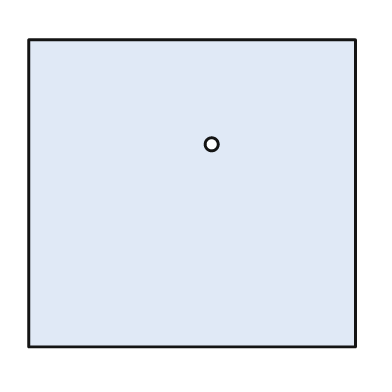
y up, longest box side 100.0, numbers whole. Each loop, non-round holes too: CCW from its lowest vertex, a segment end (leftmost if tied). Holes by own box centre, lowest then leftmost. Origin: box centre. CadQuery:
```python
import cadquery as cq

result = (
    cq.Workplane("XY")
    .moveTo(-50.0, -47.0)
    .lineTo(50.0, -47.0)
    .lineTo(50.0, 47.0)
    .lineTo(-50.0, 47.0)
    .close()
    .moveTo(6.0, 15.0)
    .circle(2.0)
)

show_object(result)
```